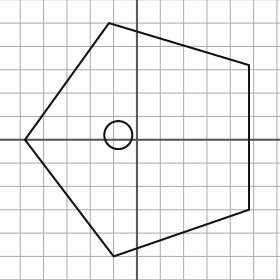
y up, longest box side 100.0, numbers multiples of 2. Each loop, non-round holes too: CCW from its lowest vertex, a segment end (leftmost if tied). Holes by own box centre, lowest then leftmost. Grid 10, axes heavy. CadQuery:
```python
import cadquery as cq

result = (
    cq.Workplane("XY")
    .moveTo(-10.0, -50.0)
    .lineTo(48.0, -30.0)
    .lineTo(48.0, 32.0)
    .lineTo(-12.0, 50.0)
    .lineTo(-48.0, 0.0)
    .close()
    .moveTo(-8.0, 2.0)
    .circle(6.0)
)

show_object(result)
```